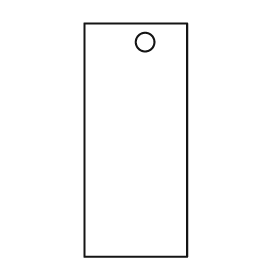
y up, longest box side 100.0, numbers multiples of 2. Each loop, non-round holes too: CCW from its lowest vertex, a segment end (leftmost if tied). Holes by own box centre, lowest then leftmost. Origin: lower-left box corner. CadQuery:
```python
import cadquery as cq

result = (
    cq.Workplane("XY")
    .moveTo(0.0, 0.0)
    .lineTo(44.0, 0.0)
    .lineTo(44.0, 100.0)
    .lineTo(0.0, 100.0)
    .close()
    .moveTo(26.0, 92.0)
    .circle(4.0)
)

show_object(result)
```